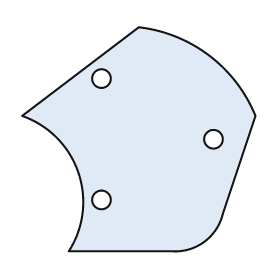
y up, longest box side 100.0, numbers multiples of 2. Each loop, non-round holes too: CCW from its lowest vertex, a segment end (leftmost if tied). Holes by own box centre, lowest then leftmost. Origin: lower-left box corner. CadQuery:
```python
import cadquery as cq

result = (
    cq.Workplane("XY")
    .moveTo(20.0, 0.0)
    .lineTo(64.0, 0.0)
    .threePointArc((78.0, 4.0), (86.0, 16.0))
    .lineTo(100.0, 58.0)
    .threePointArc((80.0, 84.0), (50.0, 96.0))
    .lineTo(0.0, 58.0)
    .threePointArc((24.0, 34.0), (20.0, 0.0))
    .close()
    .moveTo(34.0, 22.0)
    .circle(4.0)
    .moveTo(82.0, 48.0)
    .circle(4.0)
    .moveTo(34.0, 74.0)
    .circle(4.0)
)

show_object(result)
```